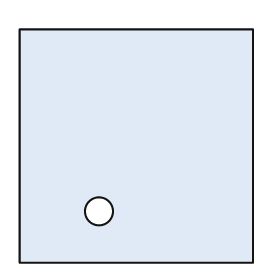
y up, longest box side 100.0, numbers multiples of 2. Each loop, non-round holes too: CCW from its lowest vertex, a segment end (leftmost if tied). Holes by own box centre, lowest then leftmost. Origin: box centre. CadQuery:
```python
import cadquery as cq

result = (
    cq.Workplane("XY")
    .moveTo(-50.0, -50.0)
    .lineTo(50.0, -50.0)
    .lineTo(50.0, 50.0)
    .lineTo(-50.0, 50.0)
    .close()
    .moveTo(-16.0, -28.0)
    .circle(6.0)
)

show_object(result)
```